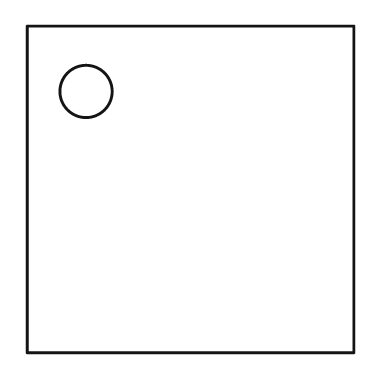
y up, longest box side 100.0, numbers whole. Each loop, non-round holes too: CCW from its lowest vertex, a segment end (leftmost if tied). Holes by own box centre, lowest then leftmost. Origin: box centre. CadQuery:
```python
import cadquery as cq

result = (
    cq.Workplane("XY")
    .moveTo(-50.0, -50.0)
    .lineTo(50.0, -50.0)
    .lineTo(50.0, 50.0)
    .lineTo(-50.0, 50.0)
    .close()
    .moveTo(-32.0, 30.0)
    .circle(8.0)
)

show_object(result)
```